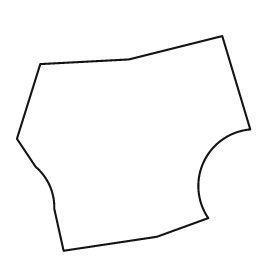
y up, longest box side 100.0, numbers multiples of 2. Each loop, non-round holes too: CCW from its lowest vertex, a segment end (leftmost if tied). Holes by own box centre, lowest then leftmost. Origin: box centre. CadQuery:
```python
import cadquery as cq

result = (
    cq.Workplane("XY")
    .moveTo(-30.0, -46.0)
    .lineTo(10.0, -40.0)
    .lineTo(32.0, -32.0)
    .threePointArc((30.0, -8.0), (50.0, 6.0))
    .lineTo(38.0, 46.0)
    .lineTo(-2.0, 36.0)
    .lineTo(-40.0, 34.0)
    .lineTo(-50.0, 2.0)
    .lineTo(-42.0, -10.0)
    .threePointArc((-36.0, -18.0), (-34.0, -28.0))
    .close()
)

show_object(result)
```